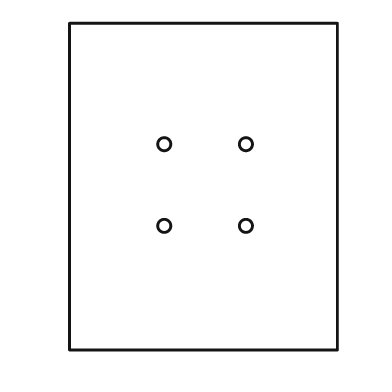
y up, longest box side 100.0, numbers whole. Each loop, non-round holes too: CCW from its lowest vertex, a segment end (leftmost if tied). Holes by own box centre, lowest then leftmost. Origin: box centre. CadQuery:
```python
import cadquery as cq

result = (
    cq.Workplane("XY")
    .moveTo(-41.0, -50.0)
    .lineTo(41.0, -50.0)
    .lineTo(41.0, 50.0)
    .lineTo(-41.0, 50.0)
    .close()
    .moveTo(-12.0, -12.0)
    .circle(2.0)
    .moveTo(13.0, -12.0)
    .circle(2.0)
    .moveTo(-12.0, 13.0)
    .circle(2.0)
    .moveTo(13.0, 13.0)
    .circle(2.0)
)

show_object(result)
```